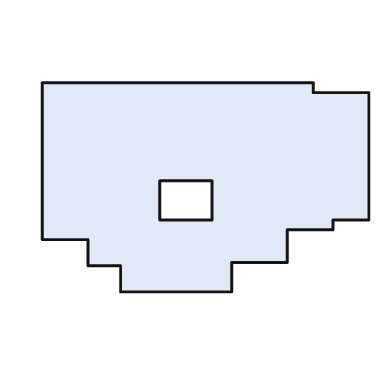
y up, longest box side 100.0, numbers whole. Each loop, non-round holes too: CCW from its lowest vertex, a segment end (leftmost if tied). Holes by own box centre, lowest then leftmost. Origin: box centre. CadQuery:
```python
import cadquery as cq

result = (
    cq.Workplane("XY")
    .moveTo(-26.0, -32.0)
    .lineTo(8.0, -32.0)
    .lineTo(8.0, -23.0)
    .lineTo(25.0, -23.0)
    .lineTo(25.0, -13.0)
    .lineTo(39.0, -13.0)
    .lineTo(39.0, -10.0)
    .lineTo(50.0, -10.0)
    .lineTo(50.0, 29.0)
    .lineTo(33.0, 29.0)
    .lineTo(33.0, 32.0)
    .lineTo(-50.0, 32.0)
    .lineTo(-50.0, -16.0)
    .lineTo(-36.0, -16.0)
    .lineTo(-36.0, -24.0)
    .lineTo(-26.0, -24.0)
    .close()
    .moveTo(-14.0, -10.0)
    .lineTo(2.0, -10.0)
    .lineTo(2.0, 2.0)
    .lineTo(-14.0, 2.0)
    .close()
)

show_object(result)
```